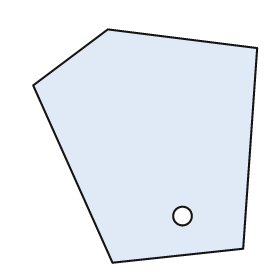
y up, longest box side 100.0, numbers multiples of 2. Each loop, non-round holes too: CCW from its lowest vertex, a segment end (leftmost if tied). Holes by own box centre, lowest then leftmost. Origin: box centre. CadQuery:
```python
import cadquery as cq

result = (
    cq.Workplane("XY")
    .moveTo(-14.0, -50.0)
    .lineTo(42.0, -44.0)
    .lineTo(48.0, 42.0)
    .lineTo(-16.0, 50.0)
    .lineTo(-48.0, 26.0)
    .close()
    .moveTo(16.0, -30.0)
    .circle(4.0)
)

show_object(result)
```